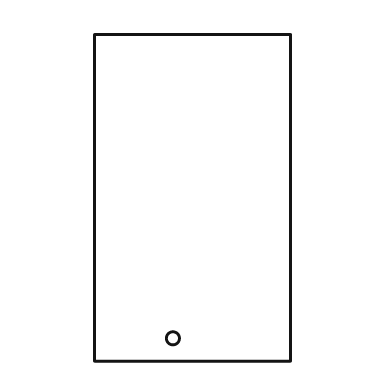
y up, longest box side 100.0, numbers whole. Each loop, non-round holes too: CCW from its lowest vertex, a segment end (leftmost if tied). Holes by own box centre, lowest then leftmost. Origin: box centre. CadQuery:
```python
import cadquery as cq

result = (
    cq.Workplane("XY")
    .moveTo(-30.0, -50.0)
    .lineTo(30.0, -50.0)
    .lineTo(30.0, 50.0)
    .lineTo(-30.0, 50.0)
    .close()
    .moveTo(-6.0, -43.0)
    .circle(2.0)
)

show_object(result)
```